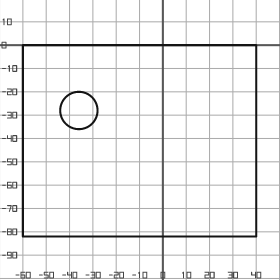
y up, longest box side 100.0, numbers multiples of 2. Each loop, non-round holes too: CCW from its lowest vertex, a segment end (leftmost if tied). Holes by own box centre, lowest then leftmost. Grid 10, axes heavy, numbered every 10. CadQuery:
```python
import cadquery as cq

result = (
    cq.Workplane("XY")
    .moveTo(-60.0, -82.0)
    .lineTo(40.0, -82.0)
    .lineTo(40.0, 0.0)
    .lineTo(-60.0, 0.0)
    .close()
    .moveTo(-36.0, -28.0)
    .circle(8.0)
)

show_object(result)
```